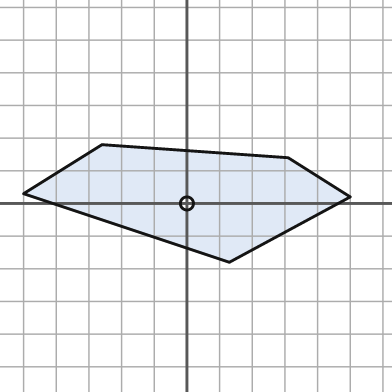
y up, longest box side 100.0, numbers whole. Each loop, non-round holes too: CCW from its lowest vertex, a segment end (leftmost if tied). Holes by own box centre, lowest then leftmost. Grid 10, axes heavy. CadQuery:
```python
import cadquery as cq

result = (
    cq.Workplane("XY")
    .moveTo(13.0, -18.0)
    .lineTo(50.0, 2.0)
    .lineTo(31.0, 14.0)
    .lineTo(-26.0, 18.0)
    .lineTo(-50.0, 3.0)
    .close()
    .moveTo(0.0, 0.0)
    .circle(2.0)
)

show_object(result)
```